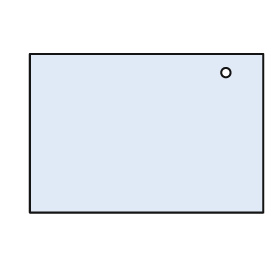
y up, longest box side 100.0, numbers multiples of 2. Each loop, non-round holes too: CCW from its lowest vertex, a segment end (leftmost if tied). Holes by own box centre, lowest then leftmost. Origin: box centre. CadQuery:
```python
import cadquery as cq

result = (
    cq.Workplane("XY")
    .moveTo(-50.0, -34.0)
    .lineTo(50.0, -34.0)
    .lineTo(50.0, 34.0)
    .lineTo(-50.0, 34.0)
    .close()
    .moveTo(34.0, 26.0)
    .circle(2.0)
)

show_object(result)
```